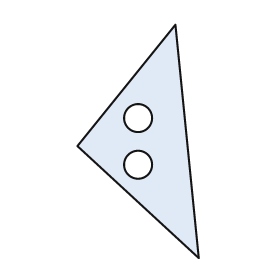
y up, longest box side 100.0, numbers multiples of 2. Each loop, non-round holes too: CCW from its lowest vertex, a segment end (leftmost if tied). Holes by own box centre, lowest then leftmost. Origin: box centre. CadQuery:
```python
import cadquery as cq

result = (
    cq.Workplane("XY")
    .moveTo(26.0, -50.0)
    .lineTo(16.0, 50.0)
    .lineTo(-26.0, -2.0)
    .close()
    .moveTo(0.0, -10.0)
    .circle(6.0)
    .moveTo(0.0, 10.0)
    .circle(6.0)
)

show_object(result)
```